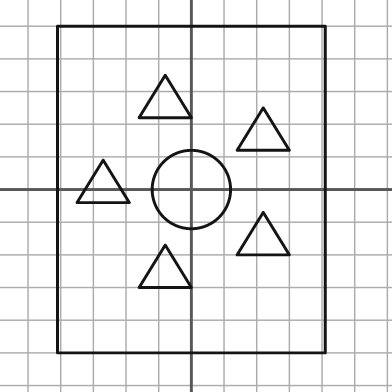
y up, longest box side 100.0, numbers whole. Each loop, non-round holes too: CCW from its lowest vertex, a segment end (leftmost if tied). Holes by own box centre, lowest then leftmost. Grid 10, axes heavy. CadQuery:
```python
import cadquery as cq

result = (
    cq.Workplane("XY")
    .moveTo(-41.0, -50.0)
    .lineTo(41.0, -50.0)
    .lineTo(41.0, 50.0)
    .lineTo(-41.0, 50.0)
    .close()
    .moveTo(-16.0, -30.0)
    .lineTo(0.0, -30.0)
    .lineTo(-8.0, -17.0)
    .close()
    .moveTo(14.0, -20.0)
    .lineTo(30.0, -20.0)
    .lineTo(22.0, -7.0)
    .close()
    .moveTo(0.0, 0.0)
    .circle(12.0)
    .moveTo(-35.0, -4.0)
    .lineTo(-19.0, -4.0)
    .lineTo(-27.0, 9.0)
    .close()
    .moveTo(14.0, 12.0)
    .lineTo(30.0, 12.0)
    .lineTo(22.0, 25.0)
    .close()
    .moveTo(-16.0, 22.0)
    .lineTo(0.0, 22.0)
    .lineTo(-8.0, 35.0)
    .close()
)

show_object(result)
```